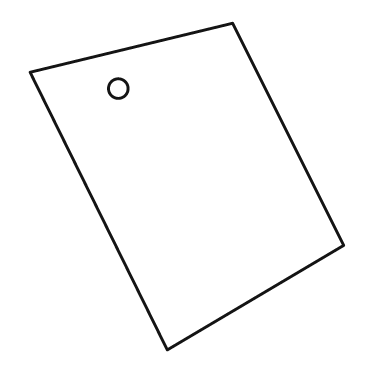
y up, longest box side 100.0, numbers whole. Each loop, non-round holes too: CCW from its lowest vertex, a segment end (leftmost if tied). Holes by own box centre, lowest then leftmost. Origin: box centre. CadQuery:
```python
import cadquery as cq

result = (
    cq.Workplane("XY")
    .moveTo(-6.0, -50.0)
    .lineTo(48.0, -18.0)
    .lineTo(14.0, 50.0)
    .lineTo(-48.0, 35.0)
    .close()
    .moveTo(-21.0, 30.0)
    .circle(3.0)
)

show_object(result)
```